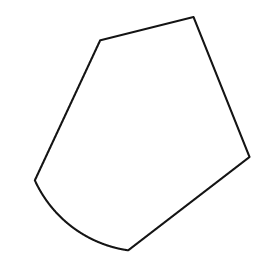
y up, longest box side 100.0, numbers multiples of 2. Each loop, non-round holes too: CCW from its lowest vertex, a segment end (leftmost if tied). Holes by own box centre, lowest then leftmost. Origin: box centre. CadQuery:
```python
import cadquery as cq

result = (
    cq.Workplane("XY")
    .moveTo(-6.0, -50.0)
    .lineTo(46.0, -10.0)
    .lineTo(22.0, 50.0)
    .lineTo(-18.0, 40.0)
    .lineTo(-46.0, -20.0)
    .threePointArc((-30.0, -40.0), (-6.0, -50.0))
    .close()
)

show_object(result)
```